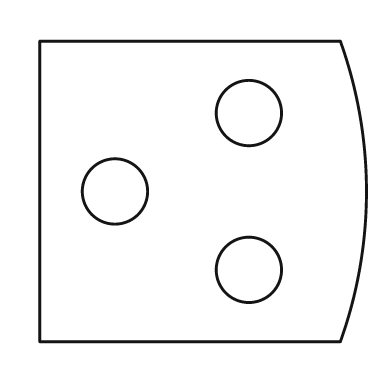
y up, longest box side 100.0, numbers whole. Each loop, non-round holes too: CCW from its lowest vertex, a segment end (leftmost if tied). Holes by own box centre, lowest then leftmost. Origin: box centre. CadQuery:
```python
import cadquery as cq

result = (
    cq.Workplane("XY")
    .moveTo(-50.0, -46.0)
    .lineTo(42.0, -46.0)
    .threePointArc((50.0, 0.0), (42.0, 46.0))
    .lineTo(-50.0, 46.0)
    .close()
    .moveTo(14.0, -24.0)
    .circle(10.0)
    .moveTo(-27.0, 0.0)
    .circle(10.0)
    .moveTo(14.0, 24.0)
    .circle(10.0)
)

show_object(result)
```